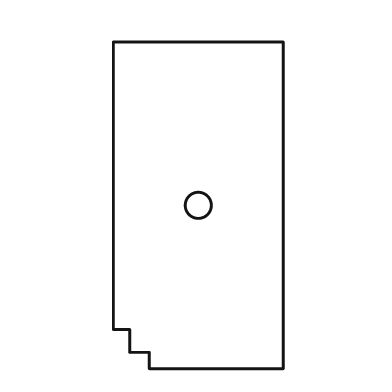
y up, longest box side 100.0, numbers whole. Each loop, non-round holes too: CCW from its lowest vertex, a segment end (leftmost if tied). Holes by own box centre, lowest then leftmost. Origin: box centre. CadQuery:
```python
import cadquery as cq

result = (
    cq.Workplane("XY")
    .moveTo(-15.0, -50.0)
    .lineTo(26.0, -50.0)
    .lineTo(26.0, 50.0)
    .lineTo(-26.0, 50.0)
    .lineTo(-26.0, -38.0)
    .lineTo(-21.0, -38.0)
    .lineTo(-21.0, -45.0)
    .lineTo(-15.0, -45.0)
    .close()
    .moveTo(0.0, 0.0)
    .circle(4.0)
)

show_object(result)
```